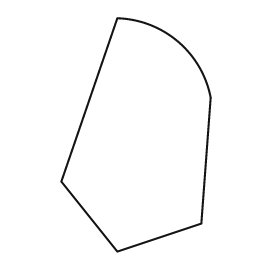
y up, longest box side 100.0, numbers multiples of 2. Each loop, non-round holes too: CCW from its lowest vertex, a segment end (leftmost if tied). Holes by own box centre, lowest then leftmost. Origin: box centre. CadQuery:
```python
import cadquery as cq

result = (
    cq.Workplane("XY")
    .moveTo(-8.0, -50.0)
    .lineTo(28.0, -38.0)
    .lineTo(32.0, 16.0)
    .threePointArc((18.0, 40.0), (-8.0, 50.0))
    .lineTo(-32.0, -20.0)
    .close()
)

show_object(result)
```